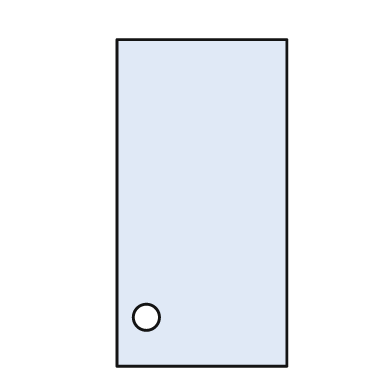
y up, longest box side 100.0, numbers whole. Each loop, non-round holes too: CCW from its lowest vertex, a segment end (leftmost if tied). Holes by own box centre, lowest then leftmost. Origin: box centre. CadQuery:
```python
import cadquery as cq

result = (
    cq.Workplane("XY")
    .moveTo(-26.0, -50.0)
    .lineTo(26.0, -50.0)
    .lineTo(26.0, 50.0)
    .lineTo(-26.0, 50.0)
    .close()
    .moveTo(-17.0, -35.0)
    .circle(4.0)
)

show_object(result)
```